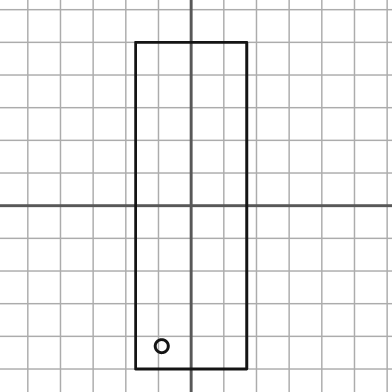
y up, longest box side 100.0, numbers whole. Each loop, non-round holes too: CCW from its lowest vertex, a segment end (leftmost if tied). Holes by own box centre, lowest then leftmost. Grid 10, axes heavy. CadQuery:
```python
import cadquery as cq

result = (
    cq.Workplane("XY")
    .moveTo(-17.0, -50.0)
    .lineTo(17.0, -50.0)
    .lineTo(17.0, 50.0)
    .lineTo(-17.0, 50.0)
    .close()
    .moveTo(-9.0, -43.0)
    .circle(2.0)
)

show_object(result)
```